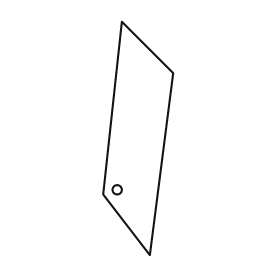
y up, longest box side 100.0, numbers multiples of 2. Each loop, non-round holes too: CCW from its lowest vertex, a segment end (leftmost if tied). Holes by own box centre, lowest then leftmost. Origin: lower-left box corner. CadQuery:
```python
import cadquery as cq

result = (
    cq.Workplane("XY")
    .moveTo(20.0, 0.0)
    .lineTo(30.0, 78.0)
    .lineTo(8.0, 100.0)
    .lineTo(0.0, 26.0)
    .close()
    .moveTo(6.0, 28.0)
    .circle(2.0)
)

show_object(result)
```